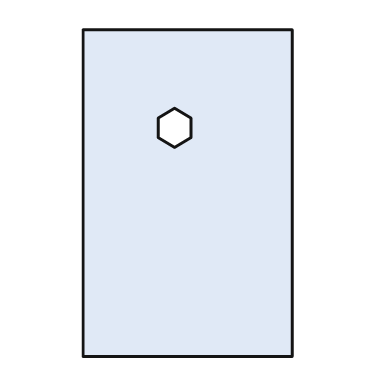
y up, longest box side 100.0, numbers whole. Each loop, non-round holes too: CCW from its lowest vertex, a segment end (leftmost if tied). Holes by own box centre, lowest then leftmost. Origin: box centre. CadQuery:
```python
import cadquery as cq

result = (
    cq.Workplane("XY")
    .moveTo(-32.0, -50.0)
    .lineTo(32.0, -50.0)
    .lineTo(32.0, 50.0)
    .lineTo(-32.0, 50.0)
    .close()
    .moveTo(-4.0, 14.0)
    .lineTo(1.0, 17.0)
    .lineTo(1.0, 23.0)
    .lineTo(-4.0, 26.0)
    .lineTo(-9.0, 23.0)
    .lineTo(-9.0, 17.0)
    .close()
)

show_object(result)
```